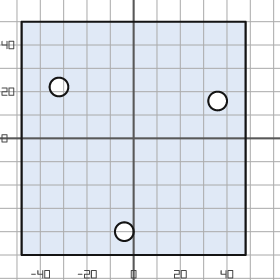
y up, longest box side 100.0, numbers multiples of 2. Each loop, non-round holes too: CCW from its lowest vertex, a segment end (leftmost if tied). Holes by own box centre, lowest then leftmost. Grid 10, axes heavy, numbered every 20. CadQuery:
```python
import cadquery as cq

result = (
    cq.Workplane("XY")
    .moveTo(-48.0, -50.0)
    .lineTo(48.0, -50.0)
    .lineTo(48.0, 50.0)
    .lineTo(-48.0, 50.0)
    .close()
    .moveTo(-4.0, -40.0)
    .circle(4.0)
    .moveTo(36.0, 16.0)
    .circle(4.0)
    .moveTo(-32.0, 22.0)
    .circle(4.0)
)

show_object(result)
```